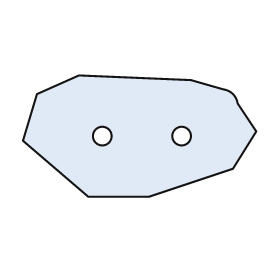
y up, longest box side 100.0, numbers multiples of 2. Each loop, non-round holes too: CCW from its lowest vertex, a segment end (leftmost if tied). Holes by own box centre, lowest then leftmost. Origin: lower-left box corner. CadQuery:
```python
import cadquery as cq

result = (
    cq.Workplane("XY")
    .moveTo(28.0, 0.0)
    .lineTo(54.0, 0.0)
    .lineTo(90.0, 12.0)
    .lineTo(100.0, 28.0)
    .lineTo(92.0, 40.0)
    .threePointArc((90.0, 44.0), (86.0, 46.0))
    .lineTo(72.0, 50.0)
    .lineTo(24.0, 52.0)
    .lineTo(6.0, 44.0)
    .lineTo(0.0, 24.0)
    .close()
    .moveTo(34.0, 26.0)
    .circle(4.0)
    .moveTo(68.0, 26.0)
    .circle(4.0)
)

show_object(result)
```